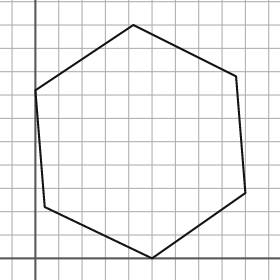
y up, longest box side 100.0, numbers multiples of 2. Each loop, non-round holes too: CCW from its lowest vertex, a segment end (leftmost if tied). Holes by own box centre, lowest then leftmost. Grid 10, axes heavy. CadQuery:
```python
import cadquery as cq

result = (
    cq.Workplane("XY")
    .moveTo(50.0, 0.0)
    .lineTo(90.0, 28.0)
    .lineTo(86.0, 78.0)
    .lineTo(42.0, 100.0)
    .lineTo(0.0, 72.0)
    .lineTo(4.0, 22.0)
    .close()
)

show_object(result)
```